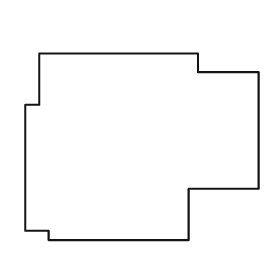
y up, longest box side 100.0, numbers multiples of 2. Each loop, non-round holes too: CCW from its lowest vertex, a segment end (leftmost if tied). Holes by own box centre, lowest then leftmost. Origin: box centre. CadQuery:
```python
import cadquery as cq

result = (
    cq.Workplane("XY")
    .moveTo(-40.0, -40.0)
    .lineTo(20.0, -40.0)
    .lineTo(20.0, -18.0)
    .lineTo(50.0, -18.0)
    .lineTo(50.0, 32.0)
    .lineTo(24.0, 32.0)
    .lineTo(24.0, 40.0)
    .lineTo(-44.0, 40.0)
    .lineTo(-44.0, 18.0)
    .lineTo(-50.0, 18.0)
    .lineTo(-50.0, -36.0)
    .lineTo(-40.0, -36.0)
    .close()
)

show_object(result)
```